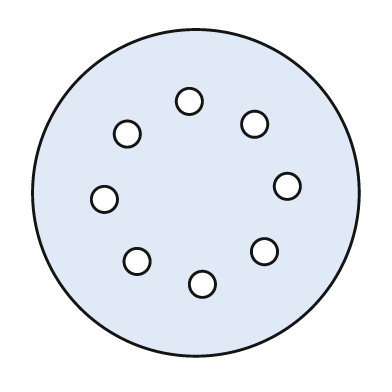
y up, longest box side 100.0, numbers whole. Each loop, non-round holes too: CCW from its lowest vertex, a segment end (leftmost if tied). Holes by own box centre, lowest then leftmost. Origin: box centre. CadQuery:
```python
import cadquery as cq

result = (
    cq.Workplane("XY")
    .moveTo(0.0, 0.0)
    .circle(50.0)
    .moveTo(2.0, -28.0)
    .circle(4.0)
    .moveTo(-18.0, -21.0)
    .circle(4.0)
    .moveTo(21.0, -18.0)
    .circle(4.0)
    .moveTo(-28.0, -2.0)
    .circle(4.0)
    .moveTo(28.0, 2.0)
    .circle(4.0)
    .moveTo(-21.0, 18.0)
    .circle(4.0)
    .moveTo(18.0, 21.0)
    .circle(4.0)
    .moveTo(-2.0, 28.0)
    .circle(4.0)
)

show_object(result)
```